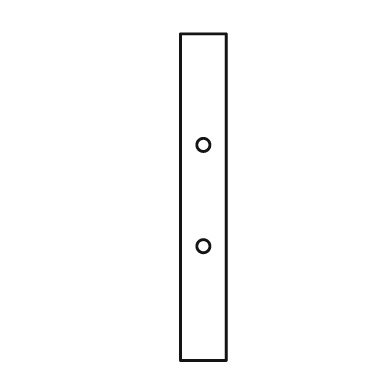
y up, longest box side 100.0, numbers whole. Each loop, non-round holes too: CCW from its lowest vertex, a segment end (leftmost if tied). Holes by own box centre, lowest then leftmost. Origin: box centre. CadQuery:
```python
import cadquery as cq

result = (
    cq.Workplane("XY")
    .moveTo(-7.0, -50.0)
    .lineTo(7.0, -50.0)
    .lineTo(7.0, 50.0)
    .lineTo(-7.0, 50.0)
    .close()
    .moveTo(0.0, -15.0)
    .circle(2.0)
    .moveTo(0.0, 16.0)
    .circle(2.0)
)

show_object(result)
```